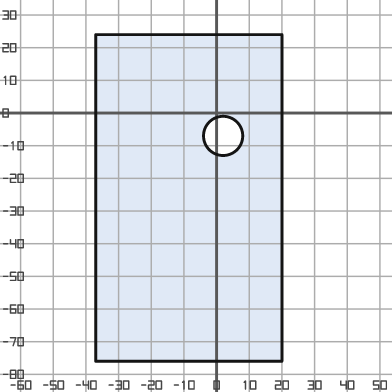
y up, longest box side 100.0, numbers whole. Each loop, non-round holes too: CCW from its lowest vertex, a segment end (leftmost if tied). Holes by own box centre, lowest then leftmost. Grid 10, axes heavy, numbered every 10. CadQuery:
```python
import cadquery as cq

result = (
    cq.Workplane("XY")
    .moveTo(-37.0, -76.0)
    .lineTo(20.0, -76.0)
    .lineTo(20.0, 24.0)
    .lineTo(-37.0, 24.0)
    .close()
    .moveTo(2.0, -7.0)
    .circle(6.0)
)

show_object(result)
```